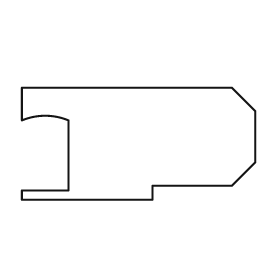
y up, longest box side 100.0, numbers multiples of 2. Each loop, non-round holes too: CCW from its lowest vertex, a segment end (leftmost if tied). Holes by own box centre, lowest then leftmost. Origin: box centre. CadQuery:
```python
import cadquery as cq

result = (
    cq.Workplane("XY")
    .moveTo(-50.0, -24.0)
    .lineTo(6.0, -24.0)
    .lineTo(6.0, -18.0)
    .lineTo(40.0, -18.0)
    .lineTo(50.0, -8.0)
    .lineTo(50.0, 14.0)
    .lineTo(40.0, 24.0)
    .lineTo(-50.0, 24.0)
    .lineTo(-50.0, 10.0)
    .threePointArc((-40.0, 12.0), (-30.0, 10.0))
    .lineTo(-30.0, -20.0)
    .lineTo(-50.0, -20.0)
    .close()
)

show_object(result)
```